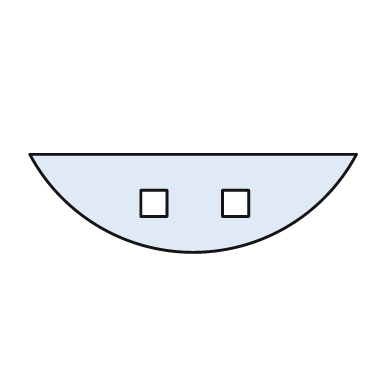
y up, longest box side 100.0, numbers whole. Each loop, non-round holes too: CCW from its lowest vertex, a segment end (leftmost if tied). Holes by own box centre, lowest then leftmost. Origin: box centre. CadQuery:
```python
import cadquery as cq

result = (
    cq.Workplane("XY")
    .moveTo(-50.0, 15.0)
    .threePointArc((0.0, -15.0), (50.0, 15.0))
    .close()
    .moveTo(-16.0, -4.0)
    .lineTo(-8.0, -4.0)
    .lineTo(-8.0, 4.0)
    .lineTo(-16.0, 4.0)
    .close()
    .moveTo(9.0, -4.0)
    .lineTo(17.0, -4.0)
    .lineTo(17.0, 4.0)
    .lineTo(9.0, 4.0)
    .close()
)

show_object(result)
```